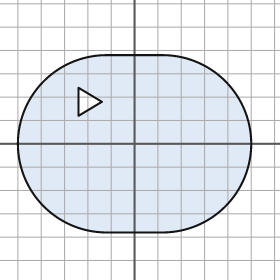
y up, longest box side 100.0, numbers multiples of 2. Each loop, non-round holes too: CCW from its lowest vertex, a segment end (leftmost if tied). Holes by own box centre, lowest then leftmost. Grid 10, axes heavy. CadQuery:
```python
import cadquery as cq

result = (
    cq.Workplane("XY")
    .moveTo(-12.0, -38.0)
    .lineTo(12.0, -38.0)
    .threePointArc((50.0, 0.0), (12.0, 38.0))
    .lineTo(-12.0, 38.0)
    .threePointArc((-50.0, 0.0), (-12.0, -38.0))
    .close()
    .moveTo(-24.0, 12.0)
    .lineTo(-14.0, 18.0)
    .lineTo(-24.0, 24.0)
    .close()
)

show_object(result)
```